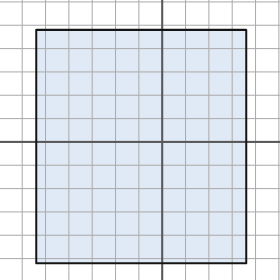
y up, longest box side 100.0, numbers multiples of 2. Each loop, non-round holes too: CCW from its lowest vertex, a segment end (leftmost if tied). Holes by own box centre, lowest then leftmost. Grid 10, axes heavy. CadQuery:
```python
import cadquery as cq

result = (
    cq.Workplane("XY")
    .moveTo(-54.0, -52.0)
    .lineTo(36.0, -52.0)
    .lineTo(36.0, 48.0)
    .lineTo(-54.0, 48.0)
    .close()
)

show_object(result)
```